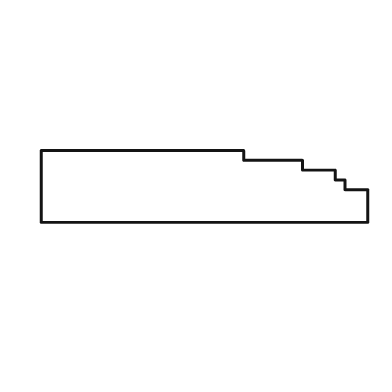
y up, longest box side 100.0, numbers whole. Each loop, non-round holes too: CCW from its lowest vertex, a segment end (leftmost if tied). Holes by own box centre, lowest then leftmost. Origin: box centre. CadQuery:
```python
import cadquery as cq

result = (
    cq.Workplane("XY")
    .moveTo(-50.0, -11.0)
    .lineTo(50.0, -11.0)
    .lineTo(50.0, -1.0)
    .lineTo(43.0, -1.0)
    .lineTo(43.0, 2.0)
    .lineTo(40.0, 2.0)
    .lineTo(40.0, 5.0)
    .lineTo(30.0, 5.0)
    .lineTo(30.0, 8.0)
    .lineTo(12.0, 8.0)
    .lineTo(12.0, 11.0)
    .lineTo(-50.0, 11.0)
    .close()
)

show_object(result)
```